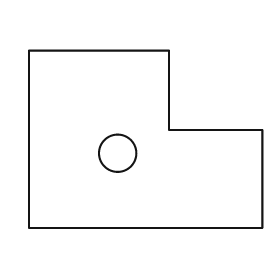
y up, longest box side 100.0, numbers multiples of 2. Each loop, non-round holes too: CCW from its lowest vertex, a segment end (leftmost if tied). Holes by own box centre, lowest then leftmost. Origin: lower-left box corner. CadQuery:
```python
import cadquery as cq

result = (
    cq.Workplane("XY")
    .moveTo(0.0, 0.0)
    .lineTo(100.0, 0.0)
    .lineTo(100.0, 42.0)
    .lineTo(60.0, 42.0)
    .lineTo(60.0, 76.0)
    .lineTo(0.0, 76.0)
    .close()
    .moveTo(38.0, 32.0)
    .circle(8.0)
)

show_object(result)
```